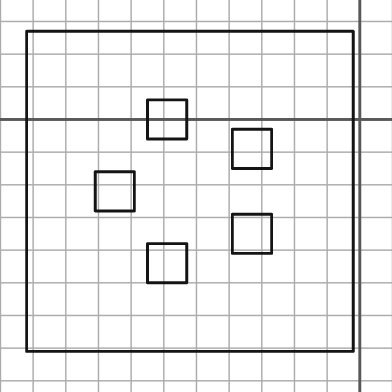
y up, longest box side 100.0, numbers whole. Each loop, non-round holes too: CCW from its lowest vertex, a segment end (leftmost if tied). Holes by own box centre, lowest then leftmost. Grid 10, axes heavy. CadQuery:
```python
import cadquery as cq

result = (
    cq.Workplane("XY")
    .moveTo(-102.0, -71.0)
    .lineTo(-2.0, -71.0)
    .lineTo(-2.0, 27.0)
    .lineTo(-102.0, 27.0)
    .close()
    .moveTo(-65.0, -50.0)
    .lineTo(-53.0, -50.0)
    .lineTo(-53.0, -38.0)
    .lineTo(-65.0, -38.0)
    .close()
    .moveTo(-39.0, -41.0)
    .lineTo(-27.0, -41.0)
    .lineTo(-27.0, -29.0)
    .lineTo(-39.0, -29.0)
    .close()
    .moveTo(-81.0, -28.0)
    .lineTo(-69.0, -28.0)
    .lineTo(-69.0, -16.0)
    .lineTo(-81.0, -16.0)
    .close()
    .moveTo(-39.0, -15.0)
    .lineTo(-27.0, -15.0)
    .lineTo(-27.0, -3.0)
    .lineTo(-39.0, -3.0)
    .close()
    .moveTo(-65.0, -6.0)
    .lineTo(-53.0, -6.0)
    .lineTo(-53.0, 6.0)
    .lineTo(-65.0, 6.0)
    .close()
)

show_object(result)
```